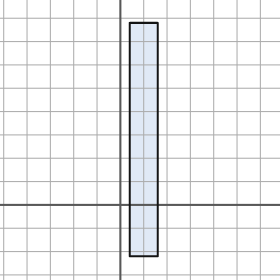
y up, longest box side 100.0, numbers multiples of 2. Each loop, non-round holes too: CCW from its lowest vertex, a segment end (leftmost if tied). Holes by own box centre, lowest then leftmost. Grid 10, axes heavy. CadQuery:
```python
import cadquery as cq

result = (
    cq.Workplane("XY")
    .moveTo(4.0, -22.0)
    .lineTo(16.0, -22.0)
    .lineTo(16.0, 78.0)
    .lineTo(4.0, 78.0)
    .close()
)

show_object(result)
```